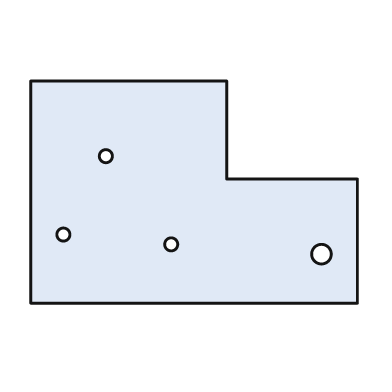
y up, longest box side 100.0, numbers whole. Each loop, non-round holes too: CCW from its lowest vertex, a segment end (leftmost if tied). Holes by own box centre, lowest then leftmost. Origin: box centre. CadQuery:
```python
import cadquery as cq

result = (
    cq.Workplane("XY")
    .moveTo(-50.0, -34.0)
    .lineTo(50.0, -34.0)
    .lineTo(50.0, 4.0)
    .lineTo(10.0, 4.0)
    .lineTo(10.0, 34.0)
    .lineTo(-50.0, 34.0)
    .close()
    .moveTo(39.0, -19.0)
    .circle(3.0)
    .moveTo(-7.0, -16.0)
    .circle(2.0)
    .moveTo(-40.0, -13.0)
    .circle(2.0)
    .moveTo(-27.0, 11.0)
    .circle(2.0)
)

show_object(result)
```